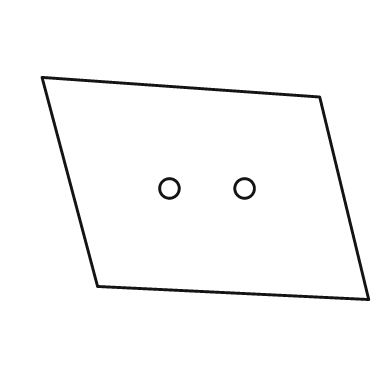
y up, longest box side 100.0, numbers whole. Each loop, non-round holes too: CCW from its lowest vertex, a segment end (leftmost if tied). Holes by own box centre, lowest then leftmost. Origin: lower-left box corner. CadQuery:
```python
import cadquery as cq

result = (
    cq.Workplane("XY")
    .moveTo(100.0, 0.0)
    .lineTo(85.0, 62.0)
    .lineTo(0.0, 68.0)
    .lineTo(17.0, 4.0)
    .close()
    .moveTo(39.0, 34.0)
    .circle(3.0)
    .moveTo(62.0, 34.0)
    .circle(3.0)
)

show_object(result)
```